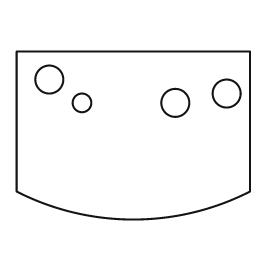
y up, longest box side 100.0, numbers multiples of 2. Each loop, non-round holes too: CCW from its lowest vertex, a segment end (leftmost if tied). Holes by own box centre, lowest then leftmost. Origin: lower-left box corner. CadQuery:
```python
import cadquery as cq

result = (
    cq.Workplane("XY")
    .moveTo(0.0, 12.0)
    .threePointArc((50.0, 0.0), (100.0, 12.0))
    .lineTo(100.0, 72.0)
    .lineTo(0.0, 72.0)
    .close()
    .moveTo(28.0, 50.0)
    .circle(4.0)
    .moveTo(68.0, 50.0)
    .circle(6.0)
    .moveTo(90.0, 54.0)
    .circle(6.0)
    .moveTo(14.0, 60.0)
    .circle(6.0)
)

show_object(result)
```